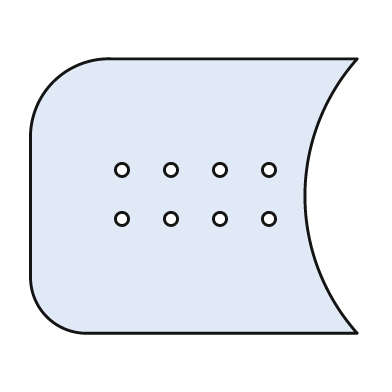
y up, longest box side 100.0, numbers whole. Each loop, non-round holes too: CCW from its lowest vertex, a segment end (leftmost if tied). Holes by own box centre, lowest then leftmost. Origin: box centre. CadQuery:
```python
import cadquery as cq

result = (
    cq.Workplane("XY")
    .moveTo(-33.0, -42.0)
    .lineTo(50.0, -42.0)
    .threePointArc((34.0, 0.0), (50.0, 42.0))
    .lineTo(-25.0, 42.0)
    .threePointArc((-43.0, 35.0), (-50.0, 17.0))
    .lineTo(-50.0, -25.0)
    .threePointArc((-45.0, -37.0), (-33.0, -42.0))
    .close()
    .moveTo(-22.0, -7.0)
    .circle(2.0)
    .moveTo(-7.0, -7.0)
    .circle(2.0)
    .moveTo(8.0, -7.0)
    .circle(2.0)
    .moveTo(23.0, -7.0)
    .circle(2.0)
    .moveTo(-22.0, 8.0)
    .circle(2.0)
    .moveTo(-7.0, 8.0)
    .circle(2.0)
    .moveTo(8.0, 8.0)
    .circle(2.0)
    .moveTo(23.0, 8.0)
    .circle(2.0)
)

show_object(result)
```